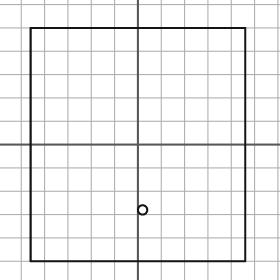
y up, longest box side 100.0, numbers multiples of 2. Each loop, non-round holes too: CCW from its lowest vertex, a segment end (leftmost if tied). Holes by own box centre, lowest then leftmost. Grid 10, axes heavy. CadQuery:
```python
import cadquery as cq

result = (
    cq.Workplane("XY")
    .moveTo(-46.0, -50.0)
    .lineTo(46.0, -50.0)
    .lineTo(46.0, 50.0)
    .lineTo(-46.0, 50.0)
    .close()
    .moveTo(2.0, -28.0)
    .circle(2.0)
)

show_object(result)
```